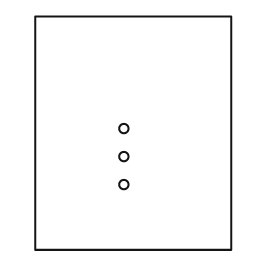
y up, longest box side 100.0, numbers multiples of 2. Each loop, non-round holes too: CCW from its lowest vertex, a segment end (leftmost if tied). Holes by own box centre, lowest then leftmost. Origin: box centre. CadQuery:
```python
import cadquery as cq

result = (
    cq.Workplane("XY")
    .moveTo(-42.0, -50.0)
    .lineTo(42.0, -50.0)
    .lineTo(42.0, 50.0)
    .lineTo(-42.0, 50.0)
    .close()
    .moveTo(-4.0, -22.0)
    .circle(2.0)
    .moveTo(-4.0, -10.0)
    .circle(2.0)
    .moveTo(-4.0, 2.0)
    .circle(2.0)
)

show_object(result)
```